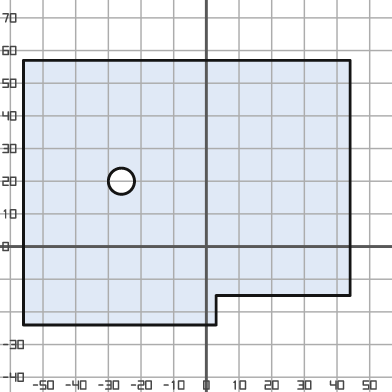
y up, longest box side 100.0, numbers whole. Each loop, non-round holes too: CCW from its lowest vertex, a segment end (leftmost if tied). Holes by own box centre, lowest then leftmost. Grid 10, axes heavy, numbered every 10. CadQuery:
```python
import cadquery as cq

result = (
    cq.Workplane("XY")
    .moveTo(-56.0, -24.0)
    .lineTo(3.0, -24.0)
    .lineTo(3.0, -15.0)
    .lineTo(44.0, -15.0)
    .lineTo(44.0, 57.0)
    .lineTo(-56.0, 57.0)
    .close()
    .moveTo(-26.0, 20.0)
    .circle(4.0)
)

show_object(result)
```